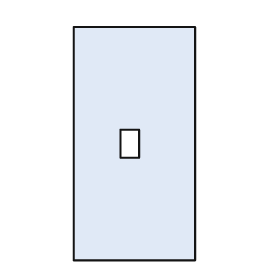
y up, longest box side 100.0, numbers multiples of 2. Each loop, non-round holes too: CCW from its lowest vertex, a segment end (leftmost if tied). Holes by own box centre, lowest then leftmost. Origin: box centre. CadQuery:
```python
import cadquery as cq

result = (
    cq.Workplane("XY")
    .moveTo(-26.0, -50.0)
    .lineTo(26.0, -50.0)
    .lineTo(26.0, 50.0)
    .lineTo(-26.0, 50.0)
    .close()
    .moveTo(-6.0, -6.0)
    .lineTo(2.0, -6.0)
    .lineTo(2.0, 6.0)
    .lineTo(-6.0, 6.0)
    .close()
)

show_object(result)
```